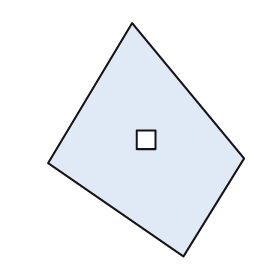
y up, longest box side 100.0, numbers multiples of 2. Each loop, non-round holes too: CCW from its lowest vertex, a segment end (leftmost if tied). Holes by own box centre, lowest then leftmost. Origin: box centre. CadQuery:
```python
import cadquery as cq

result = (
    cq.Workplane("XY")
    .moveTo(16.0, -50.0)
    .lineTo(42.0, -8.0)
    .lineTo(-6.0, 50.0)
    .lineTo(-42.0, -10.0)
    .close()
    .moveTo(-4.0, -4.0)
    .lineTo(4.0, -4.0)
    .lineTo(4.0, 4.0)
    .lineTo(-4.0, 4.0)
    .close()
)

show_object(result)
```